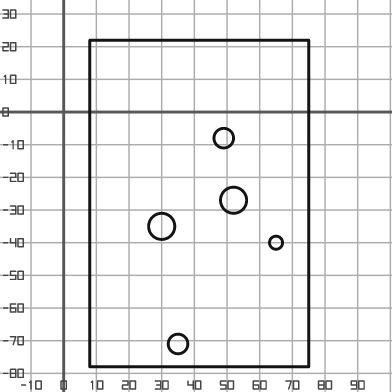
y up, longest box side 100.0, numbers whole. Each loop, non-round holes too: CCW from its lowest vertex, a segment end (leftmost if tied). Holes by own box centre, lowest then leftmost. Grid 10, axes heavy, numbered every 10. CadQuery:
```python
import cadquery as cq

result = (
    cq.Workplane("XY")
    .moveTo(8.0, -78.0)
    .lineTo(75.0, -78.0)
    .lineTo(75.0, 22.0)
    .lineTo(8.0, 22.0)
    .close()
    .moveTo(35.0, -71.0)
    .circle(3.0)
    .moveTo(65.0, -40.0)
    .circle(2.0)
    .moveTo(30.0, -35.0)
    .circle(4.0)
    .moveTo(52.0, -27.0)
    .circle(4.0)
    .moveTo(49.0, -8.0)
    .circle(3.0)
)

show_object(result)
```